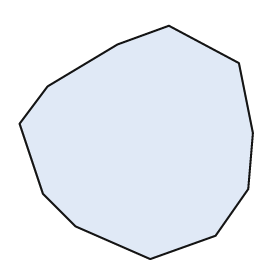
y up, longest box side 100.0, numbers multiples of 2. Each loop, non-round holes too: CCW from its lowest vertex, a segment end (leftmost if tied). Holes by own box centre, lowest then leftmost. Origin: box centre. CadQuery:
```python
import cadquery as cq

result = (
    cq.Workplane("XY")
    .moveTo(6.0, -50.0)
    .lineTo(34.0, -40.0)
    .lineTo(48.0, -20.0)
    .lineTo(50.0, 4.0)
    .lineTo(44.0, 34.0)
    .lineTo(14.0, 50.0)
    .lineTo(-8.0, 42.0)
    .lineTo(-38.0, 24.0)
    .lineTo(-50.0, 8.0)
    .lineTo(-40.0, -22.0)
    .lineTo(-26.0, -36.0)
    .close()
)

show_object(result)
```